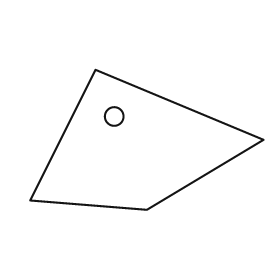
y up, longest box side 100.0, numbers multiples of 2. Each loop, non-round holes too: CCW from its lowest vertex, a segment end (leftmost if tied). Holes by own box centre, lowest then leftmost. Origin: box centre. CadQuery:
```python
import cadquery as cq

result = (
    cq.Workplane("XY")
    .moveTo(0.0, -30.0)
    .lineTo(50.0, 0.0)
    .lineTo(-22.0, 30.0)
    .lineTo(-50.0, -26.0)
    .close()
    .moveTo(-14.0, 10.0)
    .circle(4.0)
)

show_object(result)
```